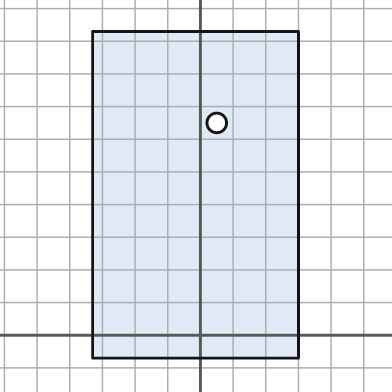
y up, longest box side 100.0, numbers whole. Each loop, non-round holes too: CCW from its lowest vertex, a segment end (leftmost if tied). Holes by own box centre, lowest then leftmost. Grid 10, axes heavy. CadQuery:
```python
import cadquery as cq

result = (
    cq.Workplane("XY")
    .moveTo(-33.0, -7.0)
    .lineTo(30.0, -7.0)
    .lineTo(30.0, 93.0)
    .lineTo(-33.0, 93.0)
    .close()
    .moveTo(5.0, 65.0)
    .circle(3.0)
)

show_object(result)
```